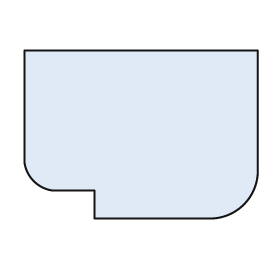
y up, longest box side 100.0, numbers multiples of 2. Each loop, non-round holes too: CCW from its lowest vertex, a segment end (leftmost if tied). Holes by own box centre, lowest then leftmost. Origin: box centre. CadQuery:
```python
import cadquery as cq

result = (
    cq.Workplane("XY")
    .moveTo(-20.0, -36.0)
    .lineTo(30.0, -36.0)
    .threePointArc((44.0, -30.0), (50.0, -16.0))
    .lineTo(50.0, 36.0)
    .lineTo(-50.0, 36.0)
    .lineTo(-50.0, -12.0)
    .threePointArc((-46.0, -20.0), (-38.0, -24.0))
    .lineTo(-20.0, -24.0)
    .close()
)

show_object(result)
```